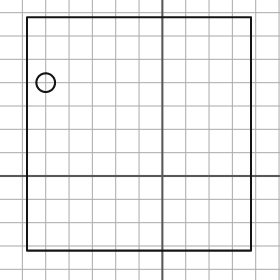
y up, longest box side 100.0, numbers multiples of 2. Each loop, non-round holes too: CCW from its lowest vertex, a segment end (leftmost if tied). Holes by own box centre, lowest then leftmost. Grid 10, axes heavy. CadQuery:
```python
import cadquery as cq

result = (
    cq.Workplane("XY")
    .moveTo(-58.0, -32.0)
    .lineTo(38.0, -32.0)
    .lineTo(38.0, 68.0)
    .lineTo(-58.0, 68.0)
    .close()
    .moveTo(-50.0, 40.0)
    .circle(4.0)
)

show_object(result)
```